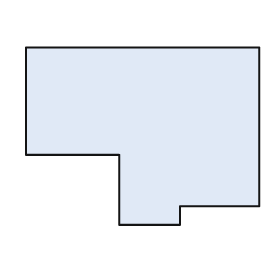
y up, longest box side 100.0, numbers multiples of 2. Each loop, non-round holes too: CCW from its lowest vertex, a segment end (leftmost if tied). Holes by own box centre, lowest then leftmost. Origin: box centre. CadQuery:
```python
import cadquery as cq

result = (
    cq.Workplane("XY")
    .moveTo(-10.0, -38.0)
    .lineTo(16.0, -38.0)
    .lineTo(16.0, -30.0)
    .lineTo(50.0, -30.0)
    .lineTo(50.0, 38.0)
    .lineTo(-50.0, 38.0)
    .lineTo(-50.0, -8.0)
    .lineTo(-10.0, -8.0)
    .close()
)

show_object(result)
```